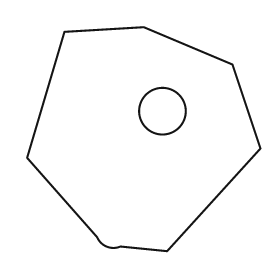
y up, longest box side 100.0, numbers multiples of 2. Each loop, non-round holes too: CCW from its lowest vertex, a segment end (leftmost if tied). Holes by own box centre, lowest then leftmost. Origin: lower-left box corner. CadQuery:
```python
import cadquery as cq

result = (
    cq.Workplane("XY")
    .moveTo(60.0, 0.0)
    .lineTo(100.0, 44.0)
    .lineTo(88.0, 80.0)
    .lineTo(50.0, 96.0)
    .lineTo(16.0, 94.0)
    .lineTo(0.0, 40.0)
    .lineTo(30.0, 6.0)
    .threePointArc((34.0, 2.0), (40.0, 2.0))
    .close()
    .moveTo(58.0, 60.0)
    .circle(10.0)
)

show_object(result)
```